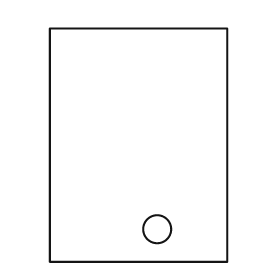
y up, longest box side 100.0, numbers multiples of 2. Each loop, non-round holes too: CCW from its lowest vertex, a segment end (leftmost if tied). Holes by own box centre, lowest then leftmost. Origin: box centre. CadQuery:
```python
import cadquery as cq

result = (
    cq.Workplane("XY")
    .moveTo(-38.0, -50.0)
    .lineTo(38.0, -50.0)
    .lineTo(38.0, 50.0)
    .lineTo(-38.0, 50.0)
    .close()
    .moveTo(8.0, -36.0)
    .circle(6.0)
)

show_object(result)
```